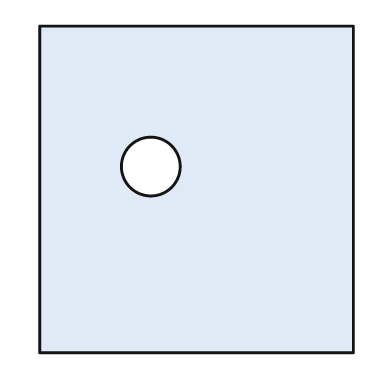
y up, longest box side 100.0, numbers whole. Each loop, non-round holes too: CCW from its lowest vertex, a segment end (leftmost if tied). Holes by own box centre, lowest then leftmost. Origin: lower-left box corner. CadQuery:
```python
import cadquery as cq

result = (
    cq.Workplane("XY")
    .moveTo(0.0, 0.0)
    .lineTo(96.0, 0.0)
    .lineTo(96.0, 100.0)
    .lineTo(0.0, 100.0)
    .close()
    .moveTo(34.0, 57.0)
    .circle(9.0)
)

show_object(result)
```